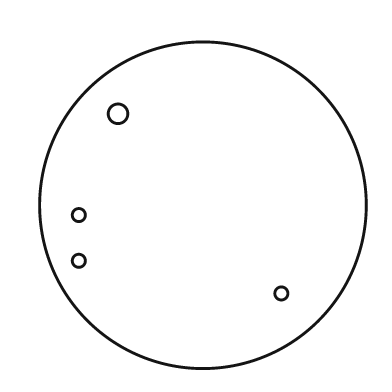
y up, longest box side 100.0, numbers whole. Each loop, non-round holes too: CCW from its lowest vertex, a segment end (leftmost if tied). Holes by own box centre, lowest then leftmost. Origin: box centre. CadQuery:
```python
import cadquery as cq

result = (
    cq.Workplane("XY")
    .moveTo(0.0, 0.0)
    .circle(50.0)
    .moveTo(24.0, -27.0)
    .circle(2.0)
    .moveTo(-38.0, -17.0)
    .circle(2.0)
    .moveTo(-38.0, -3.0)
    .circle(2.0)
    .moveTo(-26.0, 28.0)
    .circle(3.0)
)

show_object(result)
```